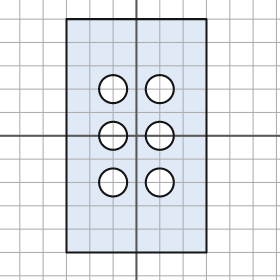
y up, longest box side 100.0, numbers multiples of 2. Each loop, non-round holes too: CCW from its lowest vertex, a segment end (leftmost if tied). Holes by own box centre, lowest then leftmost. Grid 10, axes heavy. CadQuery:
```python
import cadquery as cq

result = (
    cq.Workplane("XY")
    .moveTo(-30.0, -50.0)
    .lineTo(30.0, -50.0)
    .lineTo(30.0, 50.0)
    .lineTo(-30.0, 50.0)
    .close()
    .moveTo(-10.0, -20.0)
    .circle(6.0)
    .moveTo(10.0, -20.0)
    .circle(6.0)
    .moveTo(-10.0, 0.0)
    .circle(6.0)
    .moveTo(10.0, 0.0)
    .circle(6.0)
    .moveTo(-10.0, 20.0)
    .circle(6.0)
    .moveTo(10.0, 20.0)
    .circle(6.0)
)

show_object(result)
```